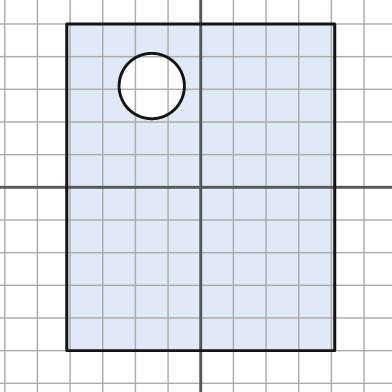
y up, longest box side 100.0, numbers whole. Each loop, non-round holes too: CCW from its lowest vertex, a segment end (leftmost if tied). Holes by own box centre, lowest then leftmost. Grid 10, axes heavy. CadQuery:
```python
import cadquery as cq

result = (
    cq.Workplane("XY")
    .moveTo(-41.0, -50.0)
    .lineTo(41.0, -50.0)
    .lineTo(41.0, 50.0)
    .lineTo(-41.0, 50.0)
    .close()
    .moveTo(-15.0, 31.0)
    .circle(10.0)
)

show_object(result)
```